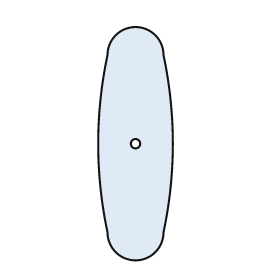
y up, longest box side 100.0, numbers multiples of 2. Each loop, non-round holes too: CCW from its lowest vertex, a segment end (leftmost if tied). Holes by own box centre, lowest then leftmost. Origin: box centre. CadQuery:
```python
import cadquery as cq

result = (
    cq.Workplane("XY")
    .moveTo(-12.0, -38.0)
    .threePointArc((0.0, -50.0), (12.0, -38.0))
    .threePointArc((16.0, 0.0), (12.0, 38.0))
    .threePointArc((0.0, 50.0), (-12.0, 38.0))
    .threePointArc((-16.0, 0.0), (-12.0, -38.0))
    .close()
    .moveTo(0.0, 0.0)
    .circle(2.0)
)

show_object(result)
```